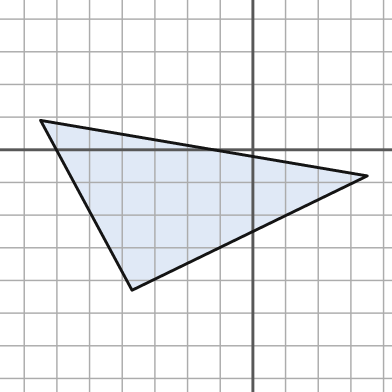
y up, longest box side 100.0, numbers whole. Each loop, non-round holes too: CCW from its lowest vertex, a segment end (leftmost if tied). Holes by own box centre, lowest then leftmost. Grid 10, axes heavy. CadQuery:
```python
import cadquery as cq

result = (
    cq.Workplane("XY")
    .moveTo(-37.0, -43.0)
    .lineTo(35.0, -8.0)
    .lineTo(-65.0, 9.0)
    .close()
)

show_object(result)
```